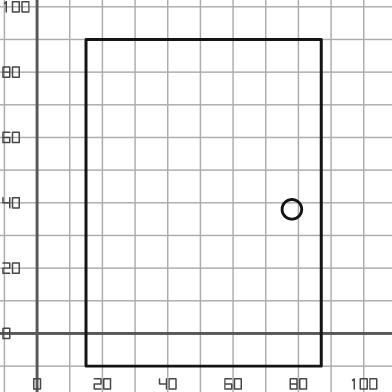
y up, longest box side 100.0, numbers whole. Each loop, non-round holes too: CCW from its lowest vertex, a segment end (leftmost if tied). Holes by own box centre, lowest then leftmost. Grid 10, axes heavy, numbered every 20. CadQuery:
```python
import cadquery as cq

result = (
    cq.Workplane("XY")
    .moveTo(15.0, -10.0)
    .lineTo(87.0, -10.0)
    .lineTo(87.0, 90.0)
    .lineTo(15.0, 90.0)
    .close()
    .moveTo(78.0, 38.0)
    .circle(3.0)
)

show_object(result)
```